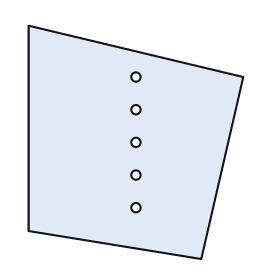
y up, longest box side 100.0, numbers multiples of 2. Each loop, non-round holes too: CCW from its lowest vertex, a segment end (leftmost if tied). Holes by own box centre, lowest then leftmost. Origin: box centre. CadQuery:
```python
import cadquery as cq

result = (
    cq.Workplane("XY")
    .moveTo(28.0, -50.0)
    .lineTo(46.0, 28.0)
    .lineTo(-46.0, 50.0)
    .lineTo(-46.0, -38.0)
    .close()
    .moveTo(0.0, -28.0)
    .circle(2.0)
    .moveTo(0.0, -14.0)
    .circle(2.0)
    .moveTo(0.0, 0.0)
    .circle(2.0)
    .moveTo(0.0, 14.0)
    .circle(2.0)
    .moveTo(0.0, 28.0)
    .circle(2.0)
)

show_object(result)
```